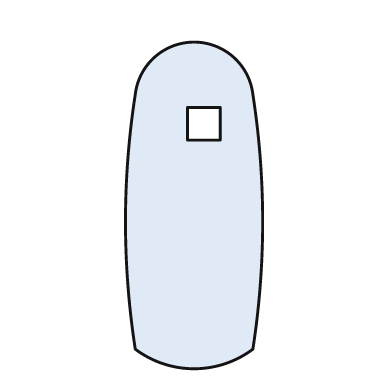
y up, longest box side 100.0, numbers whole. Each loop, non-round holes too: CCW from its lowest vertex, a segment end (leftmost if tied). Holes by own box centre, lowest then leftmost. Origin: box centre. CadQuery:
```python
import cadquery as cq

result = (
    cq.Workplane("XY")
    .moveTo(-18.0, -44.0)
    .threePointArc((0.0, -50.0), (18.0, -44.0))
    .threePointArc((21.0, -5.0), (18.0, 34.0))
    .threePointArc((0.0, 50.0), (-18.0, 34.0))
    .threePointArc((-21.0, -5.0), (-18.0, -44.0))
    .close()
    .moveTo(-2.0, 20.0)
    .lineTo(8.0, 20.0)
    .lineTo(8.0, 30.0)
    .lineTo(-2.0, 30.0)
    .close()
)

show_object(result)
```